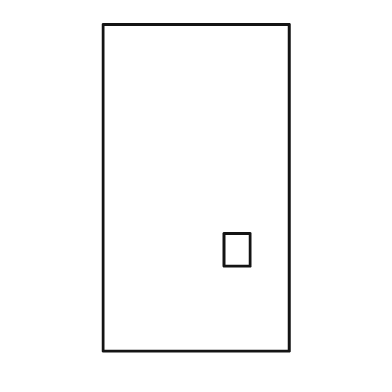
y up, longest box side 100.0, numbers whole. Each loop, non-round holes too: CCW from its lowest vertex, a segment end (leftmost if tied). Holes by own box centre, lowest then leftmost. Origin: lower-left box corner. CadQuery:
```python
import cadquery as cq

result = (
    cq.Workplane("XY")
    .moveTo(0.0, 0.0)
    .lineTo(57.0, 0.0)
    .lineTo(57.0, 100.0)
    .lineTo(0.0, 100.0)
    .close()
    .moveTo(37.0, 26.0)
    .lineTo(45.0, 26.0)
    .lineTo(45.0, 36.0)
    .lineTo(37.0, 36.0)
    .close()
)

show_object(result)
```